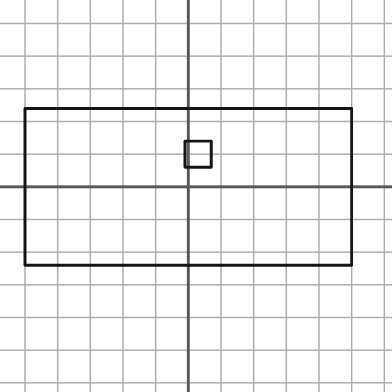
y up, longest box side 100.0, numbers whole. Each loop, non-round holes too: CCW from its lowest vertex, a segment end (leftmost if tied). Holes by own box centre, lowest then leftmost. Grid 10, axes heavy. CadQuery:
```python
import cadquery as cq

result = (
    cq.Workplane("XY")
    .moveTo(-50.0, -24.0)
    .lineTo(50.0, -24.0)
    .lineTo(50.0, 24.0)
    .lineTo(-50.0, 24.0)
    .close()
    .moveTo(-1.0, 6.0)
    .lineTo(7.0, 6.0)
    .lineTo(7.0, 14.0)
    .lineTo(-1.0, 14.0)
    .close()
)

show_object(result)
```